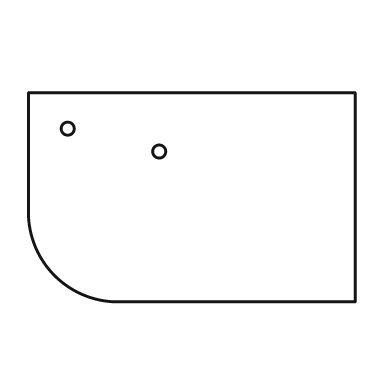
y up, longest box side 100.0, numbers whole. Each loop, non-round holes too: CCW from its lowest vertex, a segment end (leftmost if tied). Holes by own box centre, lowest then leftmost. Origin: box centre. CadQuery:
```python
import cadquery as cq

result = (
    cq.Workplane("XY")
    .moveTo(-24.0, -32.0)
    .lineTo(50.0, -32.0)
    .lineTo(50.0, 32.0)
    .lineTo(-50.0, 32.0)
    .lineTo(-50.0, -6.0)
    .threePointArc((-42.0, -24.0), (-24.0, -32.0))
    .close()
    .moveTo(-10.0, 14.0)
    .circle(2.0)
    .moveTo(-38.0, 21.0)
    .circle(2.0)
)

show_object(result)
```